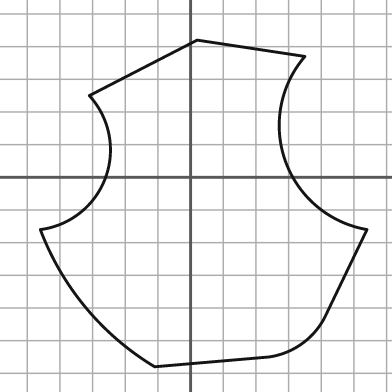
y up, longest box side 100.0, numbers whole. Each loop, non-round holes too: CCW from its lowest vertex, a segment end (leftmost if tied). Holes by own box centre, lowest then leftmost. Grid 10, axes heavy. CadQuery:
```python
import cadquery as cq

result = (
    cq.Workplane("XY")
    .moveTo(-11.0, -58.0)
    .lineTo(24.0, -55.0)
    .threePointArc((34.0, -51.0), (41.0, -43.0))
    .lineTo(54.0, -16.0)
    .threePointArc((29.0, 5.0), (35.0, 37.0))
    .lineTo(2.0, 42.0)
    .lineTo(-31.0, 25.0)
    .threePointArc((-26.0, 0.0), (-46.0, -16.0))
    .threePointArc((-32.0, -40.0), (-11.0, -58.0))
    .close()
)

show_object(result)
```